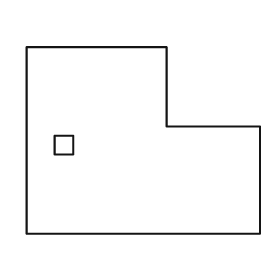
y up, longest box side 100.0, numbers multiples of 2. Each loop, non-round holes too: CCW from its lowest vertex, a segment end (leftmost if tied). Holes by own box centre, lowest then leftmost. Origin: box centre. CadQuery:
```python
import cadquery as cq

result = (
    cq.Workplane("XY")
    .moveTo(-50.0, -40.0)
    .lineTo(50.0, -40.0)
    .lineTo(50.0, 6.0)
    .lineTo(10.0, 6.0)
    .lineTo(10.0, 40.0)
    .lineTo(-50.0, 40.0)
    .close()
    .moveTo(-38.0, -6.0)
    .lineTo(-30.0, -6.0)
    .lineTo(-30.0, 2.0)
    .lineTo(-38.0, 2.0)
    .close()
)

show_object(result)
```